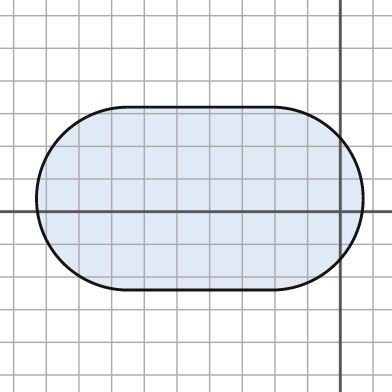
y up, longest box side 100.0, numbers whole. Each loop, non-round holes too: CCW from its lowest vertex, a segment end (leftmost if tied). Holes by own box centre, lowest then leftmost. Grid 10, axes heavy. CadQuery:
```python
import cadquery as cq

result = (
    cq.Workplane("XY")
    .moveTo(-65.0, -24.0)
    .lineTo(-21.0, -24.0)
    .threePointArc((7.0, 4.0), (-21.0, 32.0))
    .lineTo(-65.0, 32.0)
    .threePointArc((-93.0, 4.0), (-65.0, -24.0))
    .close()
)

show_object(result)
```